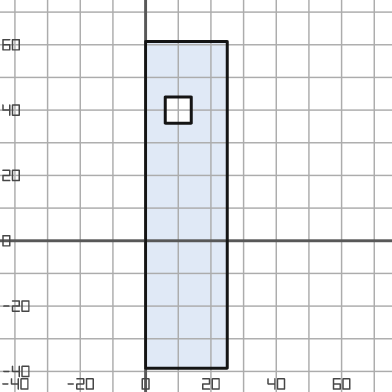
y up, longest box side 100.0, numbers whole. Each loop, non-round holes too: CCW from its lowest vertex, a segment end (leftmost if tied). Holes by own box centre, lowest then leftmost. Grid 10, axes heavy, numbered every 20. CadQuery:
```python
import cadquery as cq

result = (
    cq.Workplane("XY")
    .moveTo(0.0, -39.0)
    .lineTo(25.0, -39.0)
    .lineTo(25.0, 61.0)
    .lineTo(0.0, 61.0)
    .close()
    .moveTo(6.0, 36.0)
    .lineTo(14.0, 36.0)
    .lineTo(14.0, 44.0)
    .lineTo(6.0, 44.0)
    .close()
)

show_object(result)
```